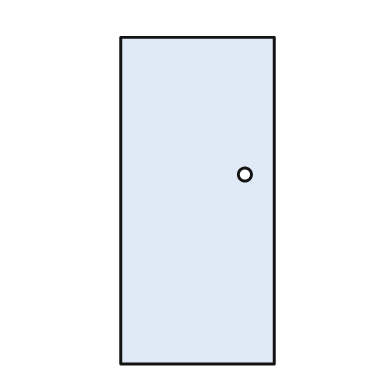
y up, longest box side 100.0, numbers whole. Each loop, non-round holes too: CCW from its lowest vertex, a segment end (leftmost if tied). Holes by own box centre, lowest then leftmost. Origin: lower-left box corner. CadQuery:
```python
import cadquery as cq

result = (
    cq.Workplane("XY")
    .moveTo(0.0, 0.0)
    .lineTo(47.0, 0.0)
    .lineTo(47.0, 100.0)
    .lineTo(0.0, 100.0)
    .close()
    .moveTo(38.0, 58.0)
    .circle(2.0)
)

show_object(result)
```